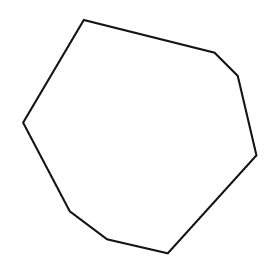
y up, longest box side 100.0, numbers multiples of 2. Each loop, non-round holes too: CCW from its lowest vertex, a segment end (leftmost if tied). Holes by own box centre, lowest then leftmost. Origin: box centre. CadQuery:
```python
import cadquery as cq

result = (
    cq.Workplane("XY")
    .moveTo(12.0, -50.0)
    .lineTo(50.0, -8.0)
    .lineTo(42.0, 26.0)
    .lineTo(32.0, 36.0)
    .lineTo(-24.0, 50.0)
    .lineTo(-50.0, 6.0)
    .lineTo(-30.0, -32.0)
    .lineTo(-14.0, -44.0)
    .close()
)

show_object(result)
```